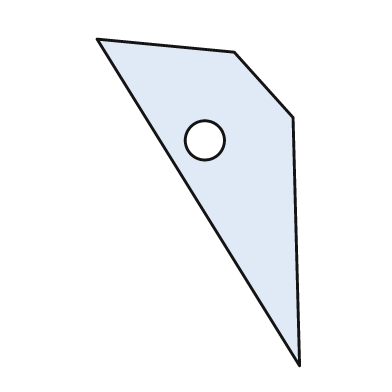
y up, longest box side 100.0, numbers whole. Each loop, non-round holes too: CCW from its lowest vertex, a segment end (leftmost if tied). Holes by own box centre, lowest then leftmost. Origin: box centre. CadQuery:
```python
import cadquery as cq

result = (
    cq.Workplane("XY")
    .moveTo(31.0, -50.0)
    .lineTo(29.0, 26.0)
    .lineTo(11.0, 46.0)
    .lineTo(-31.0, 50.0)
    .close()
    .moveTo(2.0, 19.0)
    .circle(6.0)
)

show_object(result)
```